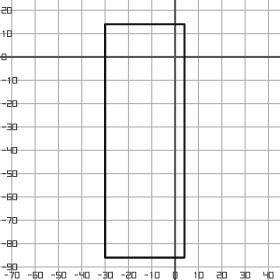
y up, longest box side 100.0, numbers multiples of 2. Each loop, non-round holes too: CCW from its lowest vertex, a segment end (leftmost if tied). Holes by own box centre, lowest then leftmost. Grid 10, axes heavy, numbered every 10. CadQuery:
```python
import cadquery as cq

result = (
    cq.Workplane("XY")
    .moveTo(-30.0, -86.0)
    .lineTo(4.0, -86.0)
    .lineTo(4.0, 14.0)
    .lineTo(-30.0, 14.0)
    .close()
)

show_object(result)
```